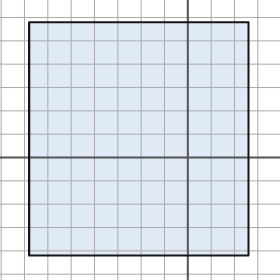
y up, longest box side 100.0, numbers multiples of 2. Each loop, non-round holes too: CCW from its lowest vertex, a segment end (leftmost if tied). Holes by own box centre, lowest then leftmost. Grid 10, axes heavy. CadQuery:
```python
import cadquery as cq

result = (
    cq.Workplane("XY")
    .moveTo(-68.0, -42.0)
    .lineTo(26.0, -42.0)
    .lineTo(26.0, 58.0)
    .lineTo(-68.0, 58.0)
    .close()
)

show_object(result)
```